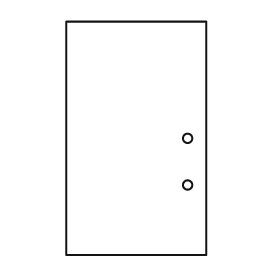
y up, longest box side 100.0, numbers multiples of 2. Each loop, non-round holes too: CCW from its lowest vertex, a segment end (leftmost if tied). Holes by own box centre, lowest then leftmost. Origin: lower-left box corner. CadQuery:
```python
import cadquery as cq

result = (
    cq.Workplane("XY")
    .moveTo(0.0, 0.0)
    .lineTo(60.0, 0.0)
    .lineTo(60.0, 100.0)
    .lineTo(0.0, 100.0)
    .close()
    .moveTo(52.0, 30.0)
    .circle(2.0)
    .moveTo(52.0, 50.0)
    .circle(2.0)
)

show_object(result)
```